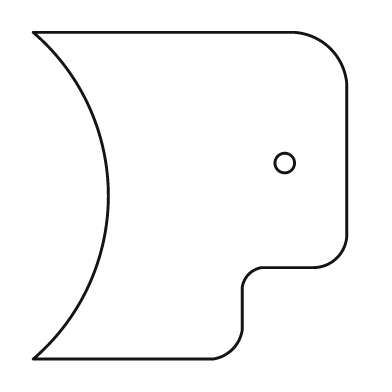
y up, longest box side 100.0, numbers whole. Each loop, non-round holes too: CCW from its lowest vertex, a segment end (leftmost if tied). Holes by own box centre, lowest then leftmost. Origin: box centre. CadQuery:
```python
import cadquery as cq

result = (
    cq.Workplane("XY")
    .moveTo(-48.0, -50.0)
    .lineTo(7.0, -50.0)
    .threePointArc((13.0, -47.0), (16.0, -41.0))
    .lineTo(16.0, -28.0)
    .threePointArc((18.0, -24.0), (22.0, -22.0))
    .lineTo(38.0, -22.0)
    .threePointArc((45.0, -19.0), (48.0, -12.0))
    .lineTo(48.0, 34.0)
    .threePointArc((43.0, 45.0), (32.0, 50.0))
    .lineTo(-48.0, 50.0)
    .threePointArc((-25.0, 0.0), (-48.0, -50.0))
    .close()
    .moveTo(29.0, 10.0)
    .circle(3.0)
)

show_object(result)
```